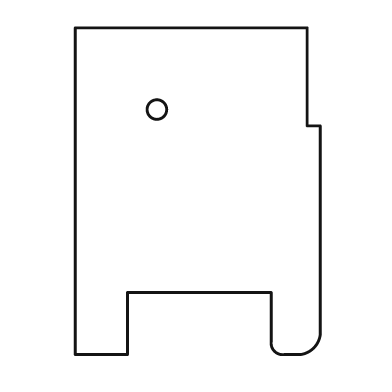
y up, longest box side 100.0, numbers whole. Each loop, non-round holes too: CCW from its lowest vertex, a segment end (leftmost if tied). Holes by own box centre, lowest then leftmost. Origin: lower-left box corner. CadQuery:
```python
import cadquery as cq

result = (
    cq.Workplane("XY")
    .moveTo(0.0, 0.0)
    .lineTo(16.0, 0.0)
    .lineTo(16.0, 19.0)
    .lineTo(60.0, 19.0)
    .lineTo(60.0, 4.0)
    .threePointArc((61.0, 1.0), (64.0, 0.0))
    .lineTo(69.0, 0.0)
    .threePointArc((73.0, 2.0), (75.0, 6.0))
    .lineTo(75.0, 70.0)
    .lineTo(71.0, 70.0)
    .lineTo(71.0, 100.0)
    .lineTo(0.0, 100.0)
    .close()
    .moveTo(25.0, 75.0)
    .circle(3.0)
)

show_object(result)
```